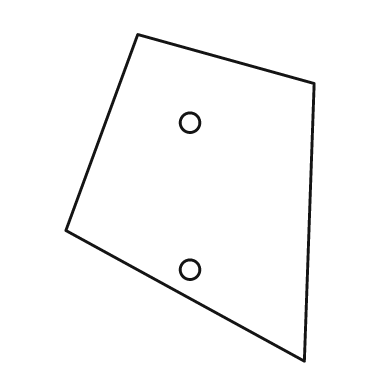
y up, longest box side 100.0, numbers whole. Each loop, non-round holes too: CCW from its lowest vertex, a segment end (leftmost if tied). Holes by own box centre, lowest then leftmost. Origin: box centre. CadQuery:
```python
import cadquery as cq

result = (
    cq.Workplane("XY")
    .moveTo(35.0, -50.0)
    .lineTo(38.0, 35.0)
    .lineTo(-16.0, 50.0)
    .lineTo(-38.0, -10.0)
    .close()
    .moveTo(0.0, -22.0)
    .circle(3.0)
    .moveTo(0.0, 23.0)
    .circle(3.0)
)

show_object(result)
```